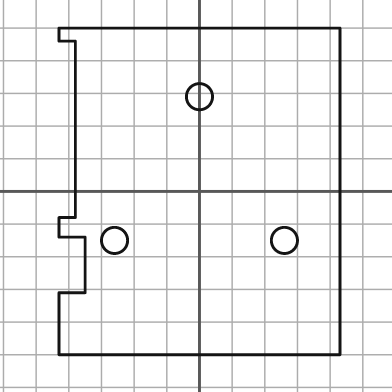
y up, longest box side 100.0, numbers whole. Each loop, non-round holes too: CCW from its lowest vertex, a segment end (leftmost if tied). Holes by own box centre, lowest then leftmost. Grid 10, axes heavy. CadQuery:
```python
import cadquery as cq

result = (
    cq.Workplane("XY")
    .moveTo(-43.0, -50.0)
    .lineTo(43.0, -50.0)
    .lineTo(43.0, 50.0)
    .lineTo(-43.0, 50.0)
    .lineTo(-43.0, 46.0)
    .lineTo(-38.0, 46.0)
    .lineTo(-38.0, -8.0)
    .lineTo(-43.0, -8.0)
    .lineTo(-43.0, -14.0)
    .lineTo(-35.0, -14.0)
    .lineTo(-35.0, -31.0)
    .lineTo(-43.0, -31.0)
    .close()
    .moveTo(-26.0, -15.0)
    .circle(4.0)
    .moveTo(26.0, -15.0)
    .circle(4.0)
    .moveTo(0.0, 29.0)
    .circle(4.0)
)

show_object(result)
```